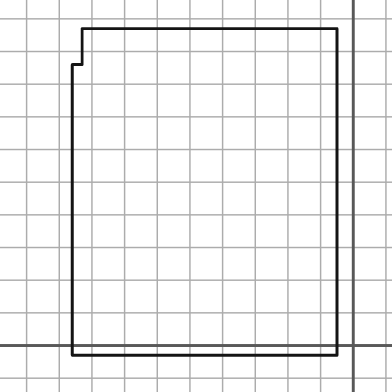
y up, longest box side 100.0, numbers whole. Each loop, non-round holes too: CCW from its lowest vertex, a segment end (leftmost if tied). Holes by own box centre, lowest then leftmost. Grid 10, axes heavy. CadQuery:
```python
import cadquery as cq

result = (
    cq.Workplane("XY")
    .moveTo(-86.0, -3.0)
    .lineTo(-5.0, -3.0)
    .lineTo(-5.0, 97.0)
    .lineTo(-83.0, 97.0)
    .lineTo(-83.0, 86.0)
    .lineTo(-86.0, 86.0)
    .close()
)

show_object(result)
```